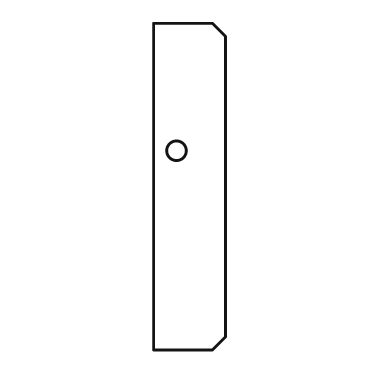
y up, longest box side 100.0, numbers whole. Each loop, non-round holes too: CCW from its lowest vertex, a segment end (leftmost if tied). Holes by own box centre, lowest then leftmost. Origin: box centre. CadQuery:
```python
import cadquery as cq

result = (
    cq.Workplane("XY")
    .moveTo(-11.0, -50.0)
    .lineTo(7.0, -50.0)
    .lineTo(11.0, -46.0)
    .lineTo(11.0, 46.0)
    .lineTo(7.0, 50.0)
    .lineTo(-11.0, 50.0)
    .close()
    .moveTo(-4.0, 11.0)
    .circle(3.0)
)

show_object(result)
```